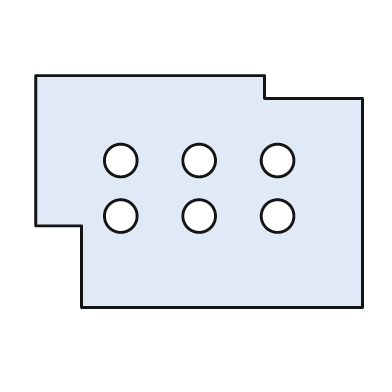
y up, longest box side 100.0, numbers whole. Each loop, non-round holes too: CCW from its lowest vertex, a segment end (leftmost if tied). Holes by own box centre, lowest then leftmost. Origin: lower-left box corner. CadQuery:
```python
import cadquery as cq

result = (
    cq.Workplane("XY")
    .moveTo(14.0, 0.0)
    .lineTo(100.0, 0.0)
    .lineTo(100.0, 64.0)
    .lineTo(70.0, 64.0)
    .lineTo(70.0, 71.0)
    .lineTo(0.0, 71.0)
    .lineTo(0.0, 25.0)
    .lineTo(14.0, 25.0)
    .close()
    .moveTo(26.0, 28.0)
    .circle(5.0)
    .moveTo(50.0, 28.0)
    .circle(5.0)
    .moveTo(74.0, 28.0)
    .circle(5.0)
    .moveTo(26.0, 45.0)
    .circle(5.0)
    .moveTo(50.0, 45.0)
    .circle(5.0)
    .moveTo(74.0, 45.0)
    .circle(5.0)
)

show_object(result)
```